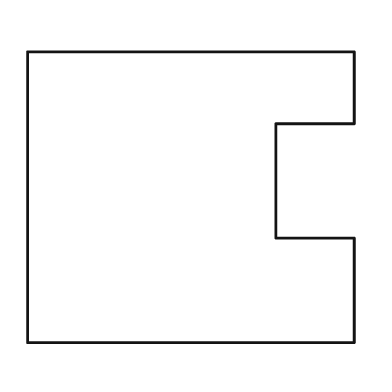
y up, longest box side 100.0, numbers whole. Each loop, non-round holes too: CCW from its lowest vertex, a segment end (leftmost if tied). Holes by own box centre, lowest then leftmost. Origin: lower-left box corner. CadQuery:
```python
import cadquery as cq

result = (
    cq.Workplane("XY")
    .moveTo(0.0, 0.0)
    .lineTo(100.0, 0.0)
    .lineTo(100.0, 32.0)
    .lineTo(76.0, 32.0)
    .lineTo(76.0, 67.0)
    .lineTo(100.0, 67.0)
    .lineTo(100.0, 89.0)
    .lineTo(0.0, 89.0)
    .close()
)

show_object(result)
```